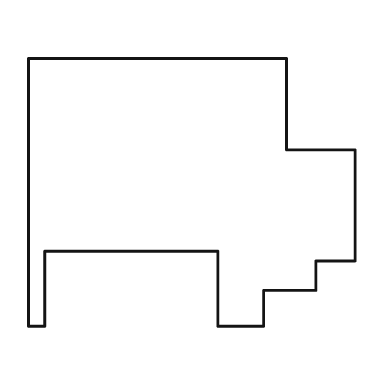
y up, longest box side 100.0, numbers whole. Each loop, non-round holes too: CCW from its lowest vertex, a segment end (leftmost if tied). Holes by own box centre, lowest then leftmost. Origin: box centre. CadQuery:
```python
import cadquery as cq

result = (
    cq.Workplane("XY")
    .moveTo(-50.0, -41.0)
    .lineTo(-45.0, -41.0)
    .lineTo(-45.0, -18.0)
    .lineTo(8.0, -18.0)
    .lineTo(8.0, -41.0)
    .lineTo(22.0, -41.0)
    .lineTo(22.0, -30.0)
    .lineTo(38.0, -30.0)
    .lineTo(38.0, -21.0)
    .lineTo(50.0, -21.0)
    .lineTo(50.0, 13.0)
    .lineTo(29.0, 13.0)
    .lineTo(29.0, 41.0)
    .lineTo(-50.0, 41.0)
    .close()
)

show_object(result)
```